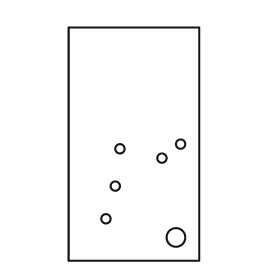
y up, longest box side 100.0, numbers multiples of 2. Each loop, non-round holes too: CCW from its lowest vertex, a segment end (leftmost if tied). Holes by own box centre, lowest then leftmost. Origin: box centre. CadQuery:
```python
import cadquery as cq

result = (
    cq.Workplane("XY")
    .moveTo(-28.0, -50.0)
    .lineTo(28.0, -50.0)
    .lineTo(28.0, 50.0)
    .lineTo(-28.0, 50.0)
    .close()
    .moveTo(18.0, -40.0)
    .circle(4.0)
    .moveTo(-12.0, -32.0)
    .circle(2.0)
    .moveTo(-8.0, -18.0)
    .circle(2.0)
    .moveTo(12.0, -6.0)
    .circle(2.0)
    .moveTo(-6.0, -2.0)
    .circle(2.0)
    .moveTo(20.0, 0.0)
    .circle(2.0)
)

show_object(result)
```